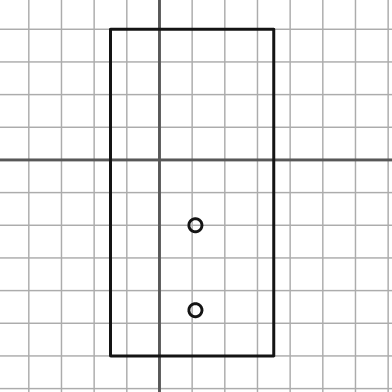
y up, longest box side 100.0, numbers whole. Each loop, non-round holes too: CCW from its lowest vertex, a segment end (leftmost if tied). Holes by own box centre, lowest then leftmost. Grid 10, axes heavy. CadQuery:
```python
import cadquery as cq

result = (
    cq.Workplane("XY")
    .moveTo(-15.0, -60.0)
    .lineTo(35.0, -60.0)
    .lineTo(35.0, 40.0)
    .lineTo(-15.0, 40.0)
    .close()
    .moveTo(11.0, -46.0)
    .circle(2.0)
    .moveTo(11.0, -20.0)
    .circle(2.0)
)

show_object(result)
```